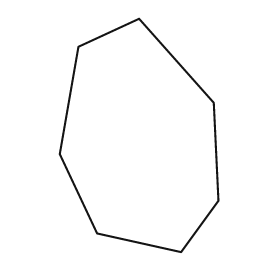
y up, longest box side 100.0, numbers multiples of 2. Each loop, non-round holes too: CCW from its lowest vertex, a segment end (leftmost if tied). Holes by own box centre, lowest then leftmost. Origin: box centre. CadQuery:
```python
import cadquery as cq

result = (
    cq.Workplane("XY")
    .moveTo(18.0, -50.0)
    .lineTo(34.0, -28.0)
    .lineTo(32.0, 14.0)
    .lineTo(0.0, 50.0)
    .lineTo(-26.0, 38.0)
    .lineTo(-34.0, -8.0)
    .lineTo(-18.0, -42.0)
    .close()
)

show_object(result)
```